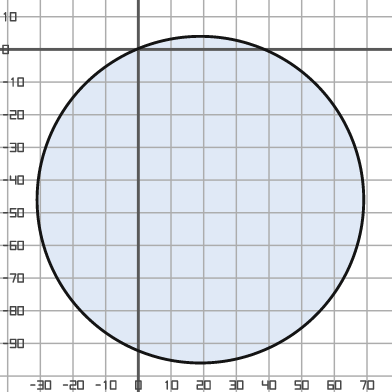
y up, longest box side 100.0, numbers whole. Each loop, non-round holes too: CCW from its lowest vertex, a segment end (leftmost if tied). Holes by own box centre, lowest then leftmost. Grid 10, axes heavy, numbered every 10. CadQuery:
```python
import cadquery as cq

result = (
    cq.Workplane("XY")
    .moveTo(19.0, -46.0)
    .circle(50.0)
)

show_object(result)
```